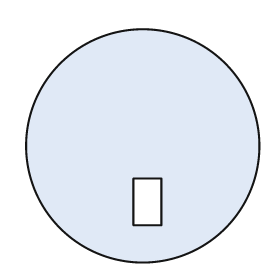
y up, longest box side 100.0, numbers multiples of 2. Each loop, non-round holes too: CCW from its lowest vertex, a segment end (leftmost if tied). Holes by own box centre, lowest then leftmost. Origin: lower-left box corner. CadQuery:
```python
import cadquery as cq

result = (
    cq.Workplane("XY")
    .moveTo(50.0, 50.0)
    .circle(50.0)
    .moveTo(46.0, 16.0)
    .lineTo(58.0, 16.0)
    .lineTo(58.0, 36.0)
    .lineTo(46.0, 36.0)
    .close()
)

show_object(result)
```